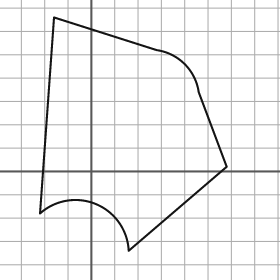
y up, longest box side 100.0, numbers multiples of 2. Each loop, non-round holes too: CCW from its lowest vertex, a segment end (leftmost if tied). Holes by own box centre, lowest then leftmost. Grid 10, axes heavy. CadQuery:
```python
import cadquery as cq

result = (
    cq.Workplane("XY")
    .moveTo(16.0, -34.0)
    .lineTo(58.0, 2.0)
    .lineTo(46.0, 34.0)
    .threePointArc((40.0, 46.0), (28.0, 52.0))
    .lineTo(-16.0, 66.0)
    .lineTo(-22.0, -18.0)
    .threePointArc((2.0, -14.0), (16.0, -34.0))
    .close()
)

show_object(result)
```